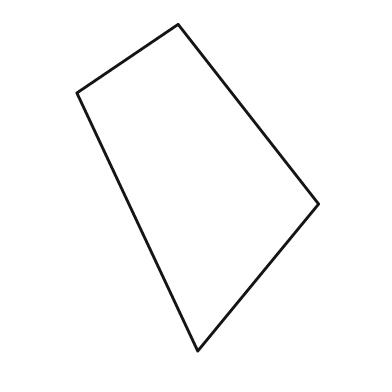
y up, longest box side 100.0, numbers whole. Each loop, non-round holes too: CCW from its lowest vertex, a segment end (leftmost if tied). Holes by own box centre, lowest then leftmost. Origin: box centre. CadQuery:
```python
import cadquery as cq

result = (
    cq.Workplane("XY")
    .moveTo(0.0, -50.0)
    .lineTo(37.0, -5.0)
    .lineTo(-6.0, 50.0)
    .lineTo(-37.0, 29.0)
    .close()
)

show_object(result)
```